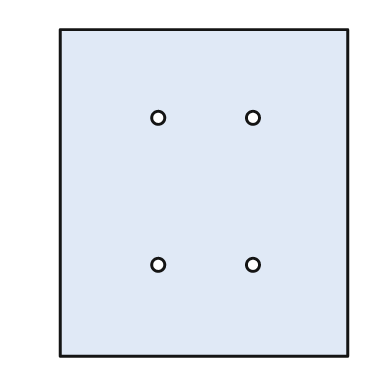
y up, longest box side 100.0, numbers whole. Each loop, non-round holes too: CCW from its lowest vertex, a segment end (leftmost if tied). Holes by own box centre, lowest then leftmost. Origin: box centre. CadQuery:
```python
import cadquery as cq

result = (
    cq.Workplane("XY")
    .moveTo(-44.0, -50.0)
    .lineTo(44.0, -50.0)
    .lineTo(44.0, 50.0)
    .lineTo(-44.0, 50.0)
    .close()
    .moveTo(-14.0, -22.0)
    .circle(2.0)
    .moveTo(15.0, -22.0)
    .circle(2.0)
    .moveTo(-14.0, 23.0)
    .circle(2.0)
    .moveTo(15.0, 23.0)
    .circle(2.0)
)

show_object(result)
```